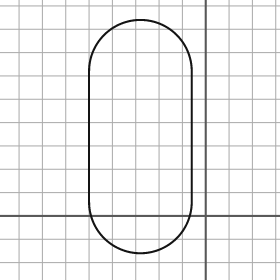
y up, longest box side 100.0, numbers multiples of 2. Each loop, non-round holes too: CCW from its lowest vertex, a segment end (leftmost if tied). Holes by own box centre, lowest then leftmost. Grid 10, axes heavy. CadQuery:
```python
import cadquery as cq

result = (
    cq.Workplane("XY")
    .moveTo(-50.0, 6.0)
    .threePointArc((-28.0, -16.0), (-6.0, 6.0))
    .lineTo(-6.0, 62.0)
    .threePointArc((-28.0, 84.0), (-50.0, 62.0))
    .close()
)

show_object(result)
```